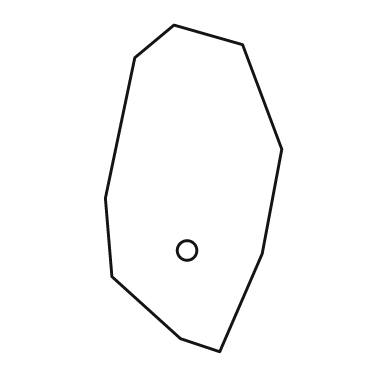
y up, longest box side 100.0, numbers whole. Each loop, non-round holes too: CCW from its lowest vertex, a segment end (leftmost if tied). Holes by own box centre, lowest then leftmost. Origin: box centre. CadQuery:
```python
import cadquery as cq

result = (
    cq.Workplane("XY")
    .moveTo(8.0, -50.0)
    .lineTo(21.0, -20.0)
    .lineTo(27.0, 12.0)
    .lineTo(15.0, 44.0)
    .lineTo(-6.0, 50.0)
    .lineTo(-18.0, 40.0)
    .lineTo(-27.0, -3.0)
    .lineTo(-25.0, -27.0)
    .lineTo(-4.0, -46.0)
    .close()
    .moveTo(-2.0, -19.0)
    .circle(3.0)
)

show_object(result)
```